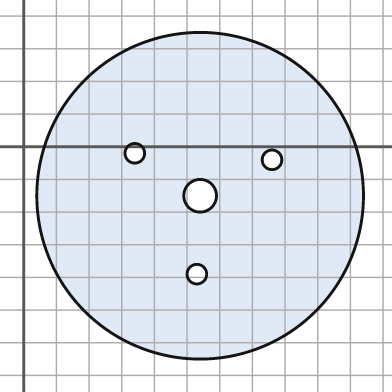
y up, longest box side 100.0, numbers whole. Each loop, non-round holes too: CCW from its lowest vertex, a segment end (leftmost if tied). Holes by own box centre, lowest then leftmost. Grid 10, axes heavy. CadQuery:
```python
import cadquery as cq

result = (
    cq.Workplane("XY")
    .moveTo(54.0, -15.0)
    .circle(50.0)
    .moveTo(53.0, -39.0)
    .circle(3.0)
    .moveTo(54.0, -15.0)
    .circle(5.0)
    .moveTo(76.0, -4.0)
    .circle(3.0)
    .moveTo(34.0, -2.0)
    .circle(3.0)
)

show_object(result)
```